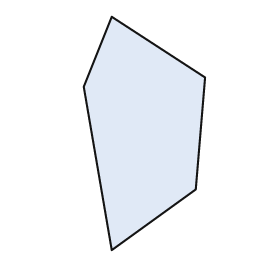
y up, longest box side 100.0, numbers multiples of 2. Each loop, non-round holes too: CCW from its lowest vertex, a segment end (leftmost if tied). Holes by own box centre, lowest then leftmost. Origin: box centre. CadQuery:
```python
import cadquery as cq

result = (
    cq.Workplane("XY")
    .moveTo(-14.0, -50.0)
    .lineTo(22.0, -24.0)
    .lineTo(26.0, 24.0)
    .lineTo(-14.0, 50.0)
    .lineTo(-26.0, 20.0)
    .close()
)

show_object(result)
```